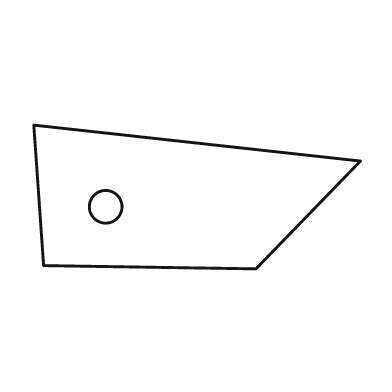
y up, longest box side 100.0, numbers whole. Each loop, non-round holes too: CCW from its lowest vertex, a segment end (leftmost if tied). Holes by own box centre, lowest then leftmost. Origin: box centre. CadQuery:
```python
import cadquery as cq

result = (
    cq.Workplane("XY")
    .moveTo(18.0, -22.0)
    .lineTo(50.0, 11.0)
    .lineTo(-50.0, 22.0)
    .lineTo(-47.0, -21.0)
    .close()
    .moveTo(-28.0, -3.0)
    .circle(5.0)
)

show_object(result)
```